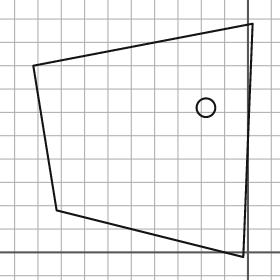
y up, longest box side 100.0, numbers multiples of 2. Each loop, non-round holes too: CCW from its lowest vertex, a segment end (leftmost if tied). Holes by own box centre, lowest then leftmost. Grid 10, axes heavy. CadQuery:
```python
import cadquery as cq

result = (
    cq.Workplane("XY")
    .moveTo(-2.0, -2.0)
    .lineTo(2.0, 98.0)
    .lineTo(-92.0, 80.0)
    .lineTo(-82.0, 18.0)
    .close()
    .moveTo(-18.0, 62.0)
    .circle(4.0)
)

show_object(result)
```